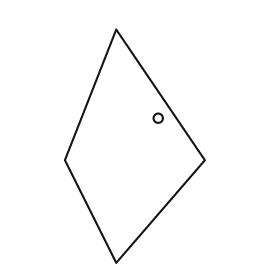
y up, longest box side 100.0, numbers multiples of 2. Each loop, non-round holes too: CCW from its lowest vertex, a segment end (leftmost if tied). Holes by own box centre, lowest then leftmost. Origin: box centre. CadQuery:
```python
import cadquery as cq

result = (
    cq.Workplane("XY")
    .moveTo(-8.0, -50.0)
    .lineTo(30.0, -6.0)
    .lineTo(-8.0, 50.0)
    .lineTo(-30.0, -6.0)
    .close()
    .moveTo(10.0, 12.0)
    .circle(2.0)
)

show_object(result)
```